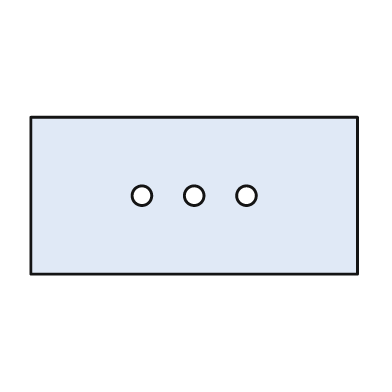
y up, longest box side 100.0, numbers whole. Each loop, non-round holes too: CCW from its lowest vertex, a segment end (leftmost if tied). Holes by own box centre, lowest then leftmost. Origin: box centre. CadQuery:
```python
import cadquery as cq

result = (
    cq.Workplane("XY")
    .moveTo(-50.0, -24.0)
    .lineTo(50.0, -24.0)
    .lineTo(50.0, 24.0)
    .lineTo(-50.0, 24.0)
    .close()
    .moveTo(-16.0, 0.0)
    .circle(3.0)
    .moveTo(0.0, 0.0)
    .circle(3.0)
    .moveTo(16.0, 0.0)
    .circle(3.0)
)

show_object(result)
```